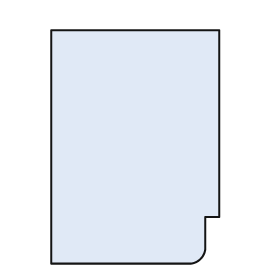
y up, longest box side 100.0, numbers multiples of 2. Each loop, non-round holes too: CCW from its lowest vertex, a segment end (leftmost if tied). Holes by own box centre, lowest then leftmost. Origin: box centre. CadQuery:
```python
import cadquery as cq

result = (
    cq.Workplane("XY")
    .moveTo(-36.0, -50.0)
    .lineTo(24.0, -50.0)
    .threePointArc((28.0, -48.0), (30.0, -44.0))
    .lineTo(30.0, -30.0)
    .lineTo(36.0, -30.0)
    .lineTo(36.0, 50.0)
    .lineTo(-36.0, 50.0)
    .close()
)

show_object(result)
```